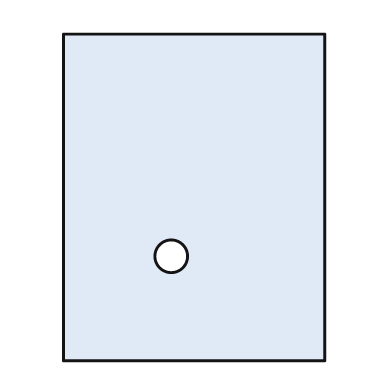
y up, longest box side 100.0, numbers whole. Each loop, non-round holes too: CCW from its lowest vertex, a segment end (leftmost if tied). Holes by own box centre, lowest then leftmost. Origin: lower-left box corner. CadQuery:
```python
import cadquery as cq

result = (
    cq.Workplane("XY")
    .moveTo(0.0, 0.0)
    .lineTo(80.0, 0.0)
    .lineTo(80.0, 100.0)
    .lineTo(0.0, 100.0)
    .close()
    .moveTo(33.0, 32.0)
    .circle(5.0)
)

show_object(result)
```